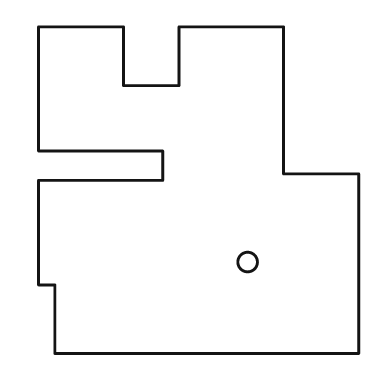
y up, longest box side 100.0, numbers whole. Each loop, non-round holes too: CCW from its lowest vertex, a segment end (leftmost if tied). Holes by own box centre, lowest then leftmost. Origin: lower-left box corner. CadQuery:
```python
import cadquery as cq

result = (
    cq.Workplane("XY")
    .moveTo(5.0, 0.0)
    .lineTo(98.0, 0.0)
    .lineTo(98.0, 55.0)
    .lineTo(75.0, 55.0)
    .lineTo(75.0, 100.0)
    .lineTo(43.0, 100.0)
    .lineTo(43.0, 82.0)
    .lineTo(26.0, 82.0)
    .lineTo(26.0, 100.0)
    .lineTo(0.0, 100.0)
    .lineTo(0.0, 62.0)
    .lineTo(38.0, 62.0)
    .lineTo(38.0, 53.0)
    .lineTo(0.0, 53.0)
    .lineTo(0.0, 21.0)
    .lineTo(5.0, 21.0)
    .close()
    .moveTo(64.0, 28.0)
    .circle(3.0)
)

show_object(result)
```